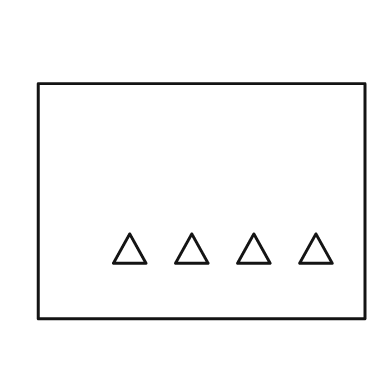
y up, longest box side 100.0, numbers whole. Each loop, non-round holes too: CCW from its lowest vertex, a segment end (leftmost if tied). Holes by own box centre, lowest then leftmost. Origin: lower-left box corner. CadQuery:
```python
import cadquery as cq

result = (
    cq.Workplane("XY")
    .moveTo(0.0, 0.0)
    .lineTo(100.0, 0.0)
    .lineTo(100.0, 72.0)
    .lineTo(0.0, 72.0)
    .close()
    .moveTo(23.0, 17.0)
    .lineTo(33.0, 17.0)
    .lineTo(28.0, 26.0)
    .close()
    .moveTo(42.0, 17.0)
    .lineTo(52.0, 17.0)
    .lineTo(47.0, 26.0)
    .close()
    .moveTo(61.0, 17.0)
    .lineTo(71.0, 17.0)
    .lineTo(66.0, 26.0)
    .close()
    .moveTo(80.0, 17.0)
    .lineTo(90.0, 17.0)
    .lineTo(85.0, 26.0)
    .close()
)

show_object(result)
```